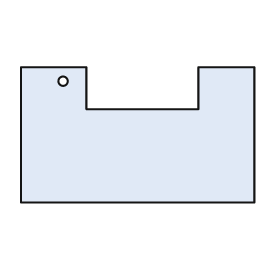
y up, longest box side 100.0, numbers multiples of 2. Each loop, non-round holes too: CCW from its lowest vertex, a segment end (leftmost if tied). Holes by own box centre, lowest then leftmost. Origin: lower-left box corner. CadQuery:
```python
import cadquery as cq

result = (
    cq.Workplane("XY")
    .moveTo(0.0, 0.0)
    .lineTo(100.0, 0.0)
    .lineTo(100.0, 58.0)
    .lineTo(76.0, 58.0)
    .lineTo(76.0, 40.0)
    .lineTo(28.0, 40.0)
    .lineTo(28.0, 58.0)
    .lineTo(0.0, 58.0)
    .close()
    .moveTo(18.0, 52.0)
    .circle(2.0)
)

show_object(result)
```